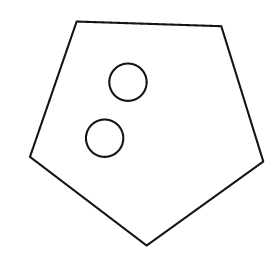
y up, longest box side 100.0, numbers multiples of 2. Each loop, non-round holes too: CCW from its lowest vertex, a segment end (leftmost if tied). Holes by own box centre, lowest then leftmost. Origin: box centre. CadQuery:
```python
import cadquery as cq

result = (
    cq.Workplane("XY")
    .moveTo(0.0, -48.0)
    .lineTo(50.0, -12.0)
    .lineTo(32.0, 46.0)
    .lineTo(-30.0, 48.0)
    .lineTo(-50.0, -10.0)
    .close()
    .moveTo(-18.0, -2.0)
    .circle(8.0)
    .moveTo(-8.0, 22.0)
    .circle(8.0)
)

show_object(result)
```